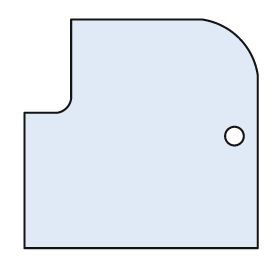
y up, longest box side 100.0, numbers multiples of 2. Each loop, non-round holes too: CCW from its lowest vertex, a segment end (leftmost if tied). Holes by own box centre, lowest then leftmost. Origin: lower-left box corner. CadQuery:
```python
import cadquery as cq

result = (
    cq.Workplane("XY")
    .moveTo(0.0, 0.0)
    .lineTo(100.0, 0.0)
    .lineTo(100.0, 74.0)
    .threePointArc((92.0, 90.0), (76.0, 98.0))
    .lineTo(20.0, 98.0)
    .lineTo(20.0, 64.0)
    .threePointArc((18.0, 60.0), (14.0, 58.0))
    .lineTo(0.0, 58.0)
    .close()
    .moveTo(90.0, 48.0)
    .circle(4.0)
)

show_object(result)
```